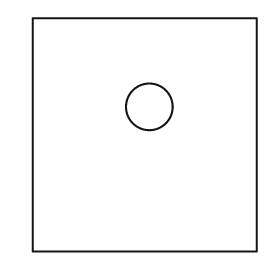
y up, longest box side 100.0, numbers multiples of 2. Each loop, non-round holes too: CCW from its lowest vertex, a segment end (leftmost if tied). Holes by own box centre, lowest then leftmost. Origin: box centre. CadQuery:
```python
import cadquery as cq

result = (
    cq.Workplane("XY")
    .moveTo(-48.0, -50.0)
    .lineTo(48.0, -50.0)
    .lineTo(48.0, 50.0)
    .lineTo(-48.0, 50.0)
    .close()
    .moveTo(2.0, 12.0)
    .circle(10.0)
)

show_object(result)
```